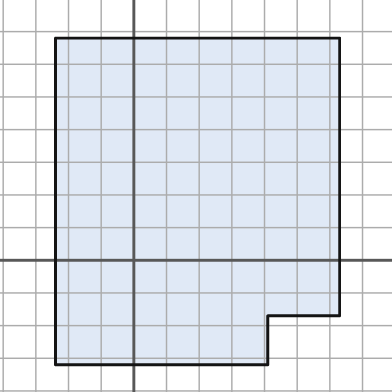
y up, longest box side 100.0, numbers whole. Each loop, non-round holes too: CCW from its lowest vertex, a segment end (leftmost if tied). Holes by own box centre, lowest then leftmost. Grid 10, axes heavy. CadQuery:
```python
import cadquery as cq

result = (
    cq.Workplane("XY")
    .moveTo(-24.0, -32.0)
    .lineTo(41.0, -32.0)
    .lineTo(41.0, -17.0)
    .lineTo(63.0, -17.0)
    .lineTo(63.0, 68.0)
    .lineTo(-24.0, 68.0)
    .close()
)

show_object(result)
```